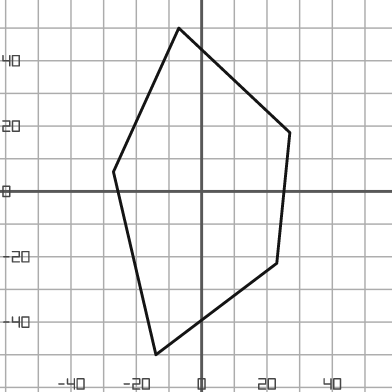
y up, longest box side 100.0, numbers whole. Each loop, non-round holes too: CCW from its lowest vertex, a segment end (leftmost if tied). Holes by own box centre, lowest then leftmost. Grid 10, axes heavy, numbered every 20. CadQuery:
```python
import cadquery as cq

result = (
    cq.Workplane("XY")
    .moveTo(-14.0, -50.0)
    .lineTo(23.0, -22.0)
    .lineTo(27.0, 18.0)
    .lineTo(-7.0, 50.0)
    .lineTo(-27.0, 6.0)
    .close()
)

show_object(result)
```